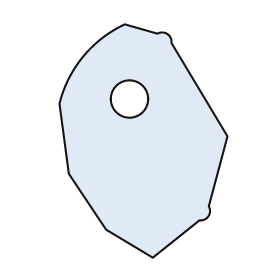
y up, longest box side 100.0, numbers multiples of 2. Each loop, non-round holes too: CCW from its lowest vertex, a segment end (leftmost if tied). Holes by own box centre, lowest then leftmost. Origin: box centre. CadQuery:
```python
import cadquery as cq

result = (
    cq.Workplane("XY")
    .moveTo(4.0, -50.0)
    .lineTo(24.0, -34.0)
    .threePointArc((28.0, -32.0), (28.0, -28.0))
    .lineTo(36.0, 2.0)
    .lineTo(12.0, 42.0)
    .threePointArc((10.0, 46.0), (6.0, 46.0))
    .lineTo(-8.0, 50.0)
    .threePointArc((-26.0, 36.0), (-36.0, 16.0))
    .lineTo(-32.0, -14.0)
    .lineTo(-16.0, -38.0)
    .close()
    .moveTo(-6.0, 18.0)
    .circle(8.0)
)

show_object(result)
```